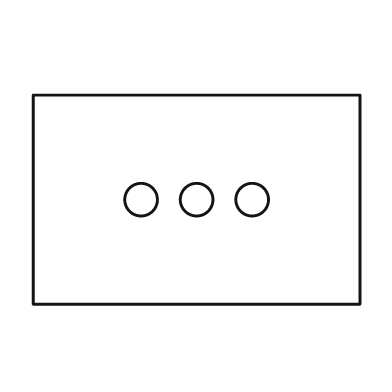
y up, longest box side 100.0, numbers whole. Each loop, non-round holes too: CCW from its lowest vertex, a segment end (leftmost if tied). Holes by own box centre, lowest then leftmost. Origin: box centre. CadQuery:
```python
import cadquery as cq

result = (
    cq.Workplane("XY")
    .moveTo(-50.0, -32.0)
    .lineTo(50.0, -32.0)
    .lineTo(50.0, 32.0)
    .lineTo(-50.0, 32.0)
    .close()
    .moveTo(-17.0, 0.0)
    .circle(5.0)
    .moveTo(0.0, 0.0)
    .circle(5.0)
    .moveTo(17.0, 0.0)
    .circle(5.0)
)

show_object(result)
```